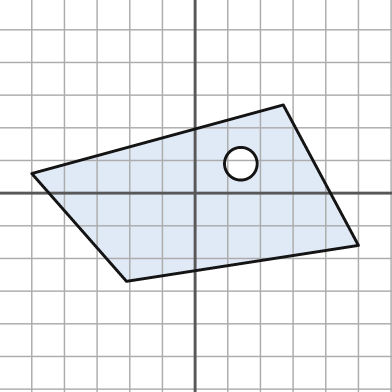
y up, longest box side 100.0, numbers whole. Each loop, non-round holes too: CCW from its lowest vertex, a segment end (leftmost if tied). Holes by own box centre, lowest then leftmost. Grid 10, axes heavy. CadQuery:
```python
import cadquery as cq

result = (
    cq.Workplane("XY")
    .moveTo(-21.0, -27.0)
    .lineTo(50.0, -16.0)
    .lineTo(27.0, 27.0)
    .lineTo(-50.0, 6.0)
    .close()
    .moveTo(14.0, 9.0)
    .circle(5.0)
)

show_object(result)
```